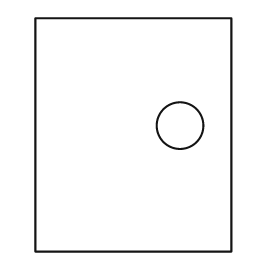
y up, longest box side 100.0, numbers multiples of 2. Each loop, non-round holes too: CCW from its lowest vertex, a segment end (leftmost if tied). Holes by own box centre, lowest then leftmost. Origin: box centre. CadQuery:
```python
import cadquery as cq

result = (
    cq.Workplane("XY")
    .moveTo(-42.0, -50.0)
    .lineTo(42.0, -50.0)
    .lineTo(42.0, 50.0)
    .lineTo(-42.0, 50.0)
    .close()
    .moveTo(20.0, 4.0)
    .circle(10.0)
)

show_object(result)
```